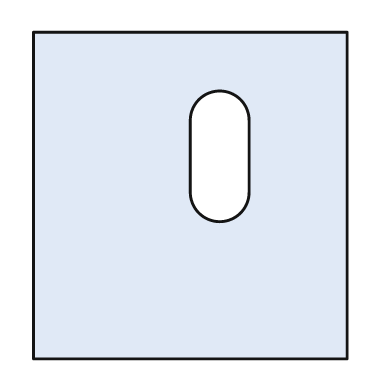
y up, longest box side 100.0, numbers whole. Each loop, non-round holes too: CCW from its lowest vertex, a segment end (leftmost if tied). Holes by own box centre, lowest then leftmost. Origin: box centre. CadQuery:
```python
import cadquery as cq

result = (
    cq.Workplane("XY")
    .moveTo(-48.0, -50.0)
    .lineTo(48.0, -50.0)
    .lineTo(48.0, 50.0)
    .lineTo(-48.0, 50.0)
    .close()
    .moveTo(0.0, 1.0)
    .threePointArc((9.0, -8.0), (18.0, 1.0))
    .lineTo(18.0, 23.0)
    .threePointArc((9.0, 32.0), (0.0, 23.0))
    .close()
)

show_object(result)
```